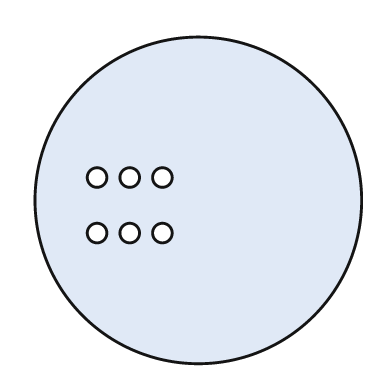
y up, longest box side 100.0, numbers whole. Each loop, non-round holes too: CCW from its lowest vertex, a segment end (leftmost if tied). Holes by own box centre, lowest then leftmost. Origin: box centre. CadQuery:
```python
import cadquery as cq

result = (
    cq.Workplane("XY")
    .moveTo(0.0, 0.0)
    .circle(50.0)
    .moveTo(-31.0, -10.0)
    .circle(3.0)
    .moveTo(-21.0, -10.0)
    .circle(3.0)
    .moveTo(-11.0, -10.0)
    .circle(3.0)
    .moveTo(-31.0, 7.0)
    .circle(3.0)
    .moveTo(-21.0, 7.0)
    .circle(3.0)
    .moveTo(-11.0, 7.0)
    .circle(3.0)
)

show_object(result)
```